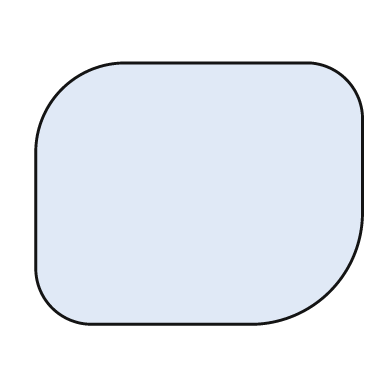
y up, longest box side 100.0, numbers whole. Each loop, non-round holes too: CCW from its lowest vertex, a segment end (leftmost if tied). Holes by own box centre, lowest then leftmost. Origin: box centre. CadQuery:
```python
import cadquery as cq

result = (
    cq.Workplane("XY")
    .moveTo(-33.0, -40.0)
    .lineTo(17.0, -40.0)
    .threePointArc((40.0, -30.0), (50.0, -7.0))
    .lineTo(50.0, 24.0)
    .threePointArc((45.0, 35.0), (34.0, 40.0))
    .lineTo(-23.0, 40.0)
    .threePointArc((-42.0, 32.0), (-50.0, 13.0))
    .lineTo(-50.0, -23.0)
    .threePointArc((-45.0, -35.0), (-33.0, -40.0))
    .close()
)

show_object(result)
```